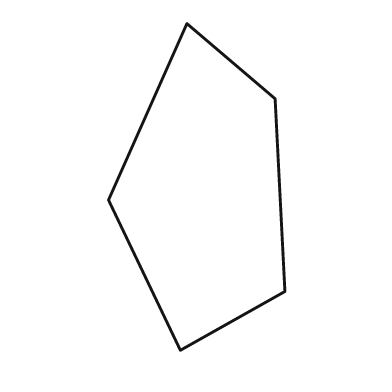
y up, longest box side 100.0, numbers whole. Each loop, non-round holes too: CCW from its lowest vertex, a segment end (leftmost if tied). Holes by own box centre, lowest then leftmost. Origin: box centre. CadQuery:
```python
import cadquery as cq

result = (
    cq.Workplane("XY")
    .moveTo(-5.0, -50.0)
    .lineTo(27.0, -32.0)
    .lineTo(24.0, 27.0)
    .lineTo(-3.0, 50.0)
    .lineTo(-27.0, -4.0)
    .close()
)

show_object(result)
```